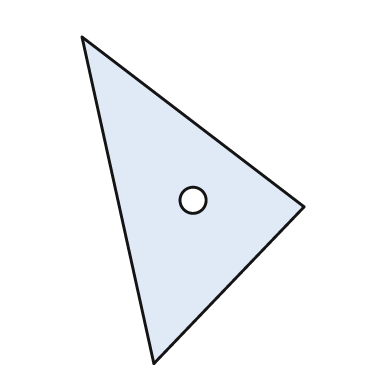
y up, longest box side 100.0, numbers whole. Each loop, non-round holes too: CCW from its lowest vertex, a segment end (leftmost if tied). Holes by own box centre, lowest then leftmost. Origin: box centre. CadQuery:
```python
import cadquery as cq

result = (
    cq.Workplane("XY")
    .moveTo(-12.0, -50.0)
    .lineTo(34.0, -2.0)
    .lineTo(-34.0, 50.0)
    .close()
    .moveTo(0.0, 0.0)
    .circle(4.0)
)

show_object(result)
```